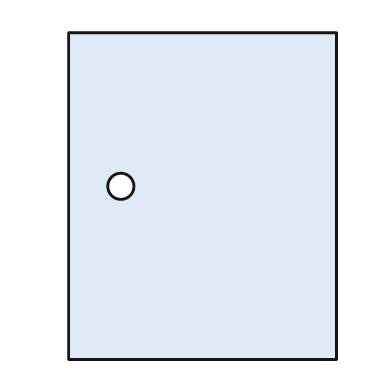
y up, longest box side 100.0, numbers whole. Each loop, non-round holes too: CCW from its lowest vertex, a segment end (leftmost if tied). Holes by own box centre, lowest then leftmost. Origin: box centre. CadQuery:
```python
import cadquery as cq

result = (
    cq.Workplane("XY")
    .moveTo(-41.0, -50.0)
    .lineTo(41.0, -50.0)
    .lineTo(41.0, 50.0)
    .lineTo(-41.0, 50.0)
    .close()
    .moveTo(-25.0, 3.0)
    .circle(4.0)
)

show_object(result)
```